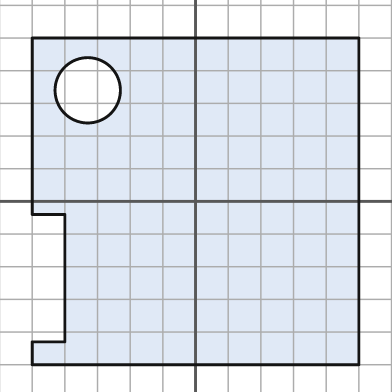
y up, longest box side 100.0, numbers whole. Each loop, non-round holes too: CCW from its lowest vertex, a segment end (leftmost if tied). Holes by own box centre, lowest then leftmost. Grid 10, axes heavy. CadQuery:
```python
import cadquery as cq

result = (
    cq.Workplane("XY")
    .moveTo(-50.0, -50.0)
    .lineTo(50.0, -50.0)
    .lineTo(50.0, 50.0)
    .lineTo(-50.0, 50.0)
    .lineTo(-50.0, -4.0)
    .lineTo(-40.0, -4.0)
    .lineTo(-40.0, -43.0)
    .lineTo(-50.0, -43.0)
    .close()
    .moveTo(-33.0, 34.0)
    .circle(10.0)
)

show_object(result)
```